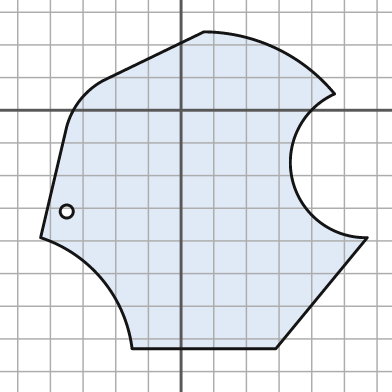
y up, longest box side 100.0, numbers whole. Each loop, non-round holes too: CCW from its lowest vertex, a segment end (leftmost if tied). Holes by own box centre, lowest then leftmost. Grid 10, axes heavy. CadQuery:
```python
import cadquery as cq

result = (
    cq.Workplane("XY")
    .moveTo(-15.0, -73.0)
    .lineTo(29.0, -73.0)
    .lineTo(57.0, -39.0)
    .threePointArc((34.0, -21.0), (47.0, 5.0))
    .threePointArc((29.0, 19.0), (7.0, 24.0))
    .lineTo(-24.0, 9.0)
    .threePointArc((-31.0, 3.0), (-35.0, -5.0))
    .lineTo(-43.0, -39.0)
    .threePointArc((-24.0, -52.0), (-15.0, -73.0))
    .close()
    .moveTo(-35.0, -31.0)
    .circle(2.0)
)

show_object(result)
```